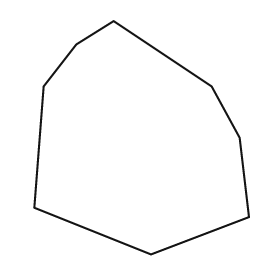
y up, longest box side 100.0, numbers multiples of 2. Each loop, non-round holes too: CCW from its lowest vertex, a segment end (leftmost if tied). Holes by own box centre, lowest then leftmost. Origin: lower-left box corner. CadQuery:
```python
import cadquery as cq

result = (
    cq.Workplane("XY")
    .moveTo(50.0, 0.0)
    .lineTo(92.0, 16.0)
    .lineTo(88.0, 50.0)
    .lineTo(76.0, 72.0)
    .lineTo(34.0, 100.0)
    .lineTo(18.0, 90.0)
    .lineTo(4.0, 72.0)
    .lineTo(0.0, 20.0)
    .close()
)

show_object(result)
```